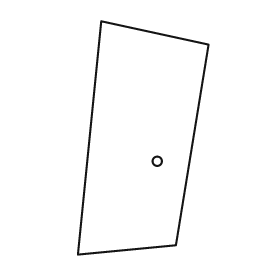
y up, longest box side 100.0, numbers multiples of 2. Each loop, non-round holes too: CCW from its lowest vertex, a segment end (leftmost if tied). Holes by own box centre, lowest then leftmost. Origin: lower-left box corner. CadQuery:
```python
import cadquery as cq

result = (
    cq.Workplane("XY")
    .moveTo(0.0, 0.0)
    .lineTo(42.0, 4.0)
    .lineTo(56.0, 90.0)
    .lineTo(10.0, 100.0)
    .close()
    .moveTo(34.0, 40.0)
    .circle(2.0)
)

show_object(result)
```